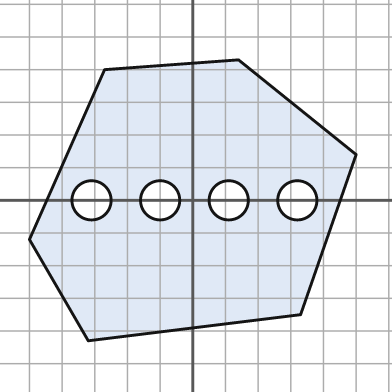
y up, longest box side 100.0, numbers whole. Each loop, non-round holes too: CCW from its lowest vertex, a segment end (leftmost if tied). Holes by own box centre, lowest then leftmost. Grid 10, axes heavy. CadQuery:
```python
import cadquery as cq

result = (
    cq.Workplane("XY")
    .moveTo(-32.0, -43.0)
    .lineTo(33.0, -35.0)
    .lineTo(50.0, 14.0)
    .lineTo(14.0, 43.0)
    .lineTo(-27.0, 40.0)
    .lineTo(-50.0, -12.0)
    .close()
    .moveTo(-31.0, 0.0)
    .circle(6.0)
    .moveTo(-10.0, 0.0)
    .circle(6.0)
    .moveTo(11.0, 0.0)
    .circle(6.0)
    .moveTo(32.0, 0.0)
    .circle(6.0)
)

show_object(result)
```